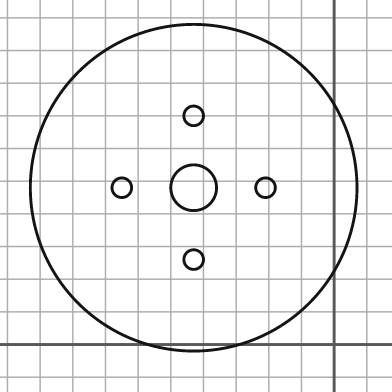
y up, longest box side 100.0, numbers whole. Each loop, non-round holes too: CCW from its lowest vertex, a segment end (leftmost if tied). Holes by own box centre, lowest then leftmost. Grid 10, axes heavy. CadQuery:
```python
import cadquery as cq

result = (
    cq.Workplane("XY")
    .moveTo(-43.0, 48.0)
    .circle(50.0)
    .moveTo(-43.0, 26.0)
    .circle(3.0)
    .moveTo(-65.0, 48.0)
    .circle(3.0)
    .moveTo(-43.0, 48.0)
    .circle(7.0)
    .moveTo(-21.0, 48.0)
    .circle(3.0)
    .moveTo(-43.0, 70.0)
    .circle(3.0)
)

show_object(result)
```